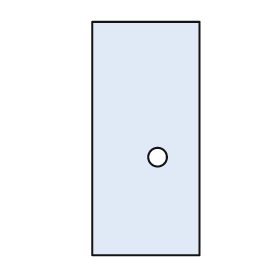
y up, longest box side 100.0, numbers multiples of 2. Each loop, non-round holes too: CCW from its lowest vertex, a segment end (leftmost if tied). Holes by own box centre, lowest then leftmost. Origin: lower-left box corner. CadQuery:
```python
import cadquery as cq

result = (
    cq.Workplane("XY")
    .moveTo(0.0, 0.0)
    .lineTo(46.0, 0.0)
    .lineTo(46.0, 100.0)
    .lineTo(0.0, 100.0)
    .close()
    .moveTo(28.0, 42.0)
    .circle(4.0)
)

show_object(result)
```